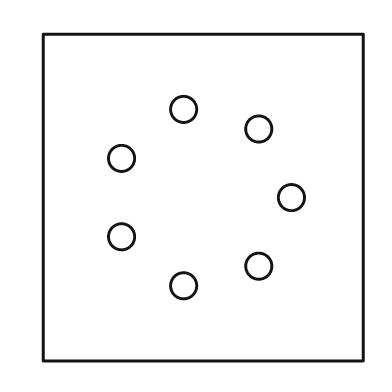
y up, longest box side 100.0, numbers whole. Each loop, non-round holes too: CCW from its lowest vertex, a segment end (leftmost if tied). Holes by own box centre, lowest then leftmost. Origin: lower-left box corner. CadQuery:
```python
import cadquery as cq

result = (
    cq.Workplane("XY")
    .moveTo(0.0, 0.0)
    .lineTo(98.0, 0.0)
    .lineTo(98.0, 100.0)
    .lineTo(0.0, 100.0)
    .close()
    .moveTo(43.0, 23.0)
    .circle(4.0)
    .moveTo(66.0, 29.0)
    .circle(4.0)
    .moveTo(24.0, 38.0)
    .circle(4.0)
    .moveTo(76.0, 50.0)
    .circle(4.0)
    .moveTo(24.0, 62.0)
    .circle(4.0)
    .moveTo(66.0, 71.0)
    .circle(4.0)
    .moveTo(43.0, 77.0)
    .circle(4.0)
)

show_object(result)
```